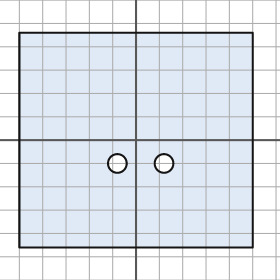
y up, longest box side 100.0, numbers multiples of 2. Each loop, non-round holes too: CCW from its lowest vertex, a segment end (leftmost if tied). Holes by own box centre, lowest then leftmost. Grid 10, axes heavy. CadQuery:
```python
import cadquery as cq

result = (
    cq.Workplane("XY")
    .moveTo(-50.0, -46.0)
    .lineTo(50.0, -46.0)
    .lineTo(50.0, 46.0)
    .lineTo(-50.0, 46.0)
    .close()
    .moveTo(-8.0, -10.0)
    .circle(4.0)
    .moveTo(12.0, -10.0)
    .circle(4.0)
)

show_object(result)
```